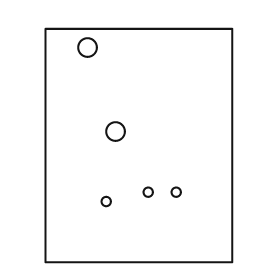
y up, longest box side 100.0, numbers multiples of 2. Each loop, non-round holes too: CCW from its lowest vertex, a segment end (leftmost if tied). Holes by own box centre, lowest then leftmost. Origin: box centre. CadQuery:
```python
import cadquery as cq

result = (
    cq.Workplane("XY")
    .moveTo(-40.0, -50.0)
    .lineTo(40.0, -50.0)
    .lineTo(40.0, 50.0)
    .lineTo(-40.0, 50.0)
    .close()
    .moveTo(-14.0, -24.0)
    .circle(2.0)
    .moveTo(4.0, -20.0)
    .circle(2.0)
    .moveTo(16.0, -20.0)
    .circle(2.0)
    .moveTo(-10.0, 6.0)
    .circle(4.0)
    .moveTo(-22.0, 42.0)
    .circle(4.0)
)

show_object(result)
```